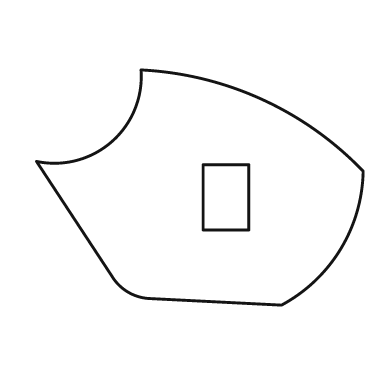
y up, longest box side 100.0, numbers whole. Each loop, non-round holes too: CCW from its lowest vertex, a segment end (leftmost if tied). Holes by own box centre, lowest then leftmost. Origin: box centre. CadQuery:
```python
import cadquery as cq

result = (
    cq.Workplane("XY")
    .moveTo(25.0, -36.0)
    .threePointArc((43.0, -19.0), (50.0, 5.0))
    .threePointArc((19.0, 27.0), (-18.0, 36.0))
    .threePointArc((-27.0, 14.0), (-50.0, 8.0))
    .lineTo(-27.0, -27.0)
    .threePointArc((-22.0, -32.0), (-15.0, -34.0))
    .close()
    .moveTo(1.0, -13.0)
    .lineTo(15.0, -13.0)
    .lineTo(15.0, 7.0)
    .lineTo(1.0, 7.0)
    .close()
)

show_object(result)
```